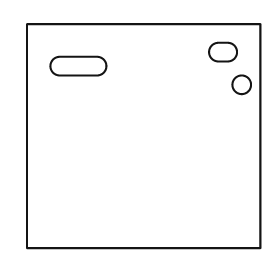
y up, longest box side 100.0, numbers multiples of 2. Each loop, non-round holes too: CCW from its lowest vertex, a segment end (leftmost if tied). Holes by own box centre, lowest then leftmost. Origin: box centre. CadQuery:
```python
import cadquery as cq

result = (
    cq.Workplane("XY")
    .moveTo(-50.0, -48.0)
    .lineTo(50.0, -48.0)
    .lineTo(50.0, 48.0)
    .lineTo(-50.0, 48.0)
    .close()
    .moveTo(42.0, 22.0)
    .circle(4.0)
    .moveTo(-36.0, 26.0)
    .lineTo(-20.0, 26.0)
    .threePointArc((-16.0, 30.0), (-20.0, 34.0))
    .lineTo(-36.0, 34.0)
    .threePointArc((-40.0, 30.0), (-36.0, 26.0))
    .close()
    .moveTo(32.0, 32.0)
    .lineTo(36.0, 32.0)
    .threePointArc((40.0, 36.0), (36.0, 40.0))
    .lineTo(32.0, 40.0)
    .threePointArc((28.0, 36.0), (32.0, 32.0))
    .close()
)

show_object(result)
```